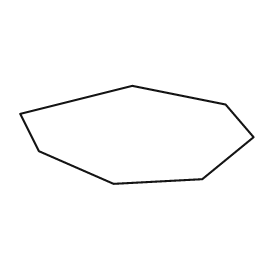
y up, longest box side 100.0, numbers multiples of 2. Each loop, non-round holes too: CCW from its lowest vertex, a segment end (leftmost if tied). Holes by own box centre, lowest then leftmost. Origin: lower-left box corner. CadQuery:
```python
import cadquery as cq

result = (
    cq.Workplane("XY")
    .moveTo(40.0, 0.0)
    .lineTo(78.0, 2.0)
    .lineTo(100.0, 20.0)
    .lineTo(88.0, 34.0)
    .lineTo(48.0, 42.0)
    .lineTo(0.0, 30.0)
    .lineTo(8.0, 14.0)
    .close()
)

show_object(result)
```